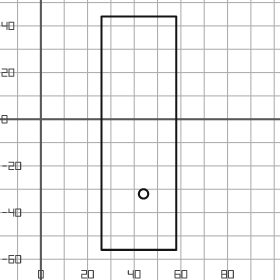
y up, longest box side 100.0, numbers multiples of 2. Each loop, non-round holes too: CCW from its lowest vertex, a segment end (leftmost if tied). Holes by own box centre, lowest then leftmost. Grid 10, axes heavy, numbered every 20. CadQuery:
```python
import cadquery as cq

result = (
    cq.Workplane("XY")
    .moveTo(26.0, -56.0)
    .lineTo(58.0, -56.0)
    .lineTo(58.0, 44.0)
    .lineTo(26.0, 44.0)
    .close()
    .moveTo(44.0, -32.0)
    .circle(2.0)
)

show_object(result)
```